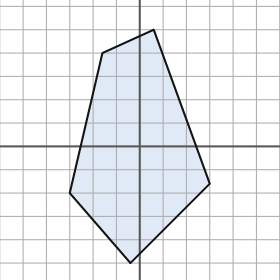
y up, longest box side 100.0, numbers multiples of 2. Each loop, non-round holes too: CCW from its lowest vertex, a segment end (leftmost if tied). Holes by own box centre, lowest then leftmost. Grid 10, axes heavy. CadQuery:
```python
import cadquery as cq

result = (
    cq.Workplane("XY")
    .moveTo(-4.0, -50.0)
    .lineTo(30.0, -16.0)
    .lineTo(6.0, 50.0)
    .lineTo(-16.0, 40.0)
    .lineTo(-30.0, -20.0)
    .close()
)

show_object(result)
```